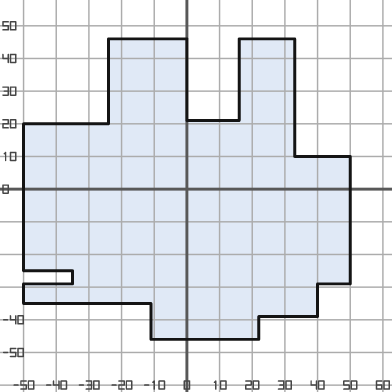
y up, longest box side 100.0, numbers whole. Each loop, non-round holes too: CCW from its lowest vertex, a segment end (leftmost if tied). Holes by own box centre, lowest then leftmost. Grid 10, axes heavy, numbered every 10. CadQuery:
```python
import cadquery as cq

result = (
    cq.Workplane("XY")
    .moveTo(-11.0, -46.0)
    .lineTo(22.0, -46.0)
    .lineTo(22.0, -39.0)
    .lineTo(40.0, -39.0)
    .lineTo(40.0, -29.0)
    .lineTo(50.0, -29.0)
    .lineTo(50.0, 10.0)
    .lineTo(33.0, 10.0)
    .lineTo(33.0, 46.0)
    .lineTo(16.0, 46.0)
    .lineTo(16.0, 21.0)
    .lineTo(0.0, 21.0)
    .lineTo(0.0, 46.0)
    .lineTo(-24.0, 46.0)
    .lineTo(-24.0, 20.0)
    .lineTo(-50.0, 20.0)
    .lineTo(-50.0, -25.0)
    .lineTo(-35.0, -25.0)
    .lineTo(-35.0, -29.0)
    .lineTo(-50.0, -29.0)
    .lineTo(-50.0, -35.0)
    .lineTo(-11.0, -35.0)
    .close()
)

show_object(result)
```